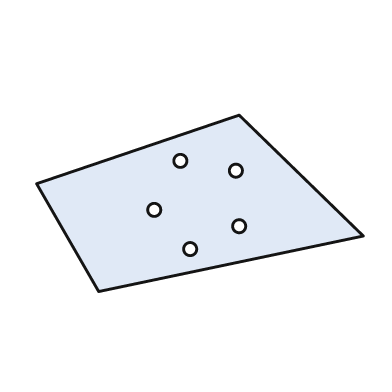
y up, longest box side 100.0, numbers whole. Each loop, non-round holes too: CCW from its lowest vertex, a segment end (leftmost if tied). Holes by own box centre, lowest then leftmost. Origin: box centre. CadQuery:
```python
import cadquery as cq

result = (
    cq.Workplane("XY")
    .moveTo(-31.0, -27.0)
    .lineTo(50.0, -10.0)
    .lineTo(12.0, 27.0)
    .lineTo(-50.0, 6.0)
    .close()
    .moveTo(-3.0, -14.0)
    .circle(2.0)
    .moveTo(12.0, -7.0)
    .circle(2.0)
    .moveTo(-14.0, -2.0)
    .circle(2.0)
    .moveTo(11.0, 10.0)
    .circle(2.0)
    .moveTo(-6.0, 13.0)
    .circle(2.0)
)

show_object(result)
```